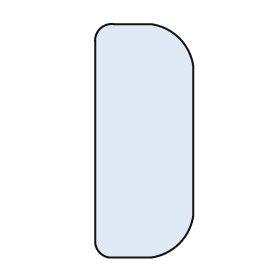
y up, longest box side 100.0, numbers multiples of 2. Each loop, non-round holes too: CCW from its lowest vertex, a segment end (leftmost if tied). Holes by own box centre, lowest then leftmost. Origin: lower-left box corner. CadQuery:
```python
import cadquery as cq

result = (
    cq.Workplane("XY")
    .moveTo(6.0, 0.0)
    .lineTo(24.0, 0.0)
    .threePointArc((36.0, 6.0), (42.0, 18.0))
    .lineTo(42.0, 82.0)
    .threePointArc((36.0, 94.0), (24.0, 100.0))
    .lineTo(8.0, 100.0)
    .threePointArc((2.0, 98.0), (0.0, 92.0))
    .lineTo(0.0, 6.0)
    .threePointArc((2.0, 2.0), (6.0, 0.0))
    .close()
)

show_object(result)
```